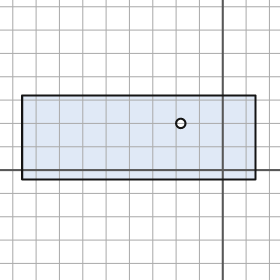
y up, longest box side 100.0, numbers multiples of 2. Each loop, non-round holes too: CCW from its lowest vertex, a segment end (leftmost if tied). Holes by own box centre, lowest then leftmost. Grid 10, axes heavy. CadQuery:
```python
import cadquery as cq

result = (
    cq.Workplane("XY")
    .moveTo(-86.0, -4.0)
    .lineTo(14.0, -4.0)
    .lineTo(14.0, 32.0)
    .lineTo(-86.0, 32.0)
    .close()
    .moveTo(-18.0, 20.0)
    .circle(2.0)
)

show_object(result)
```